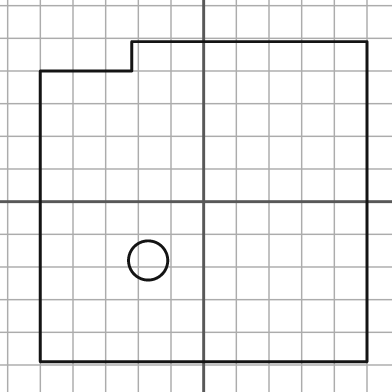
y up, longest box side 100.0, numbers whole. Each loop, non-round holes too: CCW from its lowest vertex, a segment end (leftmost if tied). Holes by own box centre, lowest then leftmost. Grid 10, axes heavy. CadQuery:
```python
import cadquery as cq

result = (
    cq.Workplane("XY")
    .moveTo(-50.0, -49.0)
    .lineTo(50.0, -49.0)
    .lineTo(50.0, 49.0)
    .lineTo(-22.0, 49.0)
    .lineTo(-22.0, 40.0)
    .lineTo(-50.0, 40.0)
    .close()
    .moveTo(-17.0, -18.0)
    .circle(6.0)
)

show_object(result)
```